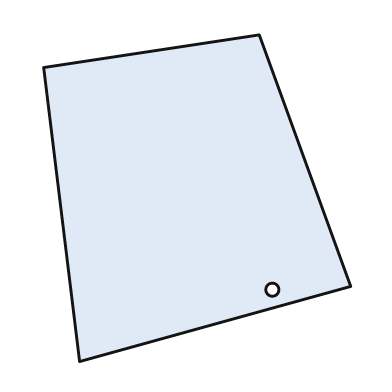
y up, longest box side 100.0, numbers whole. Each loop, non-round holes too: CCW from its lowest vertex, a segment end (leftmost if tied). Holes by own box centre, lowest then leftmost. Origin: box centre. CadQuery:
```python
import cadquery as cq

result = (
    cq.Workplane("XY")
    .moveTo(-36.0, -50.0)
    .lineTo(47.0, -27.0)
    .lineTo(19.0, 50.0)
    .lineTo(-47.0, 40.0)
    .close()
    .moveTo(23.0, -28.0)
    .circle(2.0)
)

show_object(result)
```